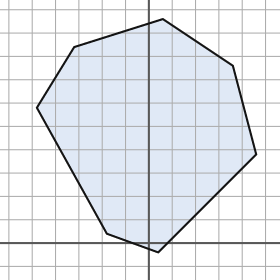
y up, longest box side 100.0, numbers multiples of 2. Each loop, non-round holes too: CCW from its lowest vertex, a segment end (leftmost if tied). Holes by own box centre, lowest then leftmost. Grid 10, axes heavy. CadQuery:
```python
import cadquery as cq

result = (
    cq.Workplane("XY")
    .moveTo(4.0, -4.0)
    .lineTo(46.0, 38.0)
    .lineTo(36.0, 76.0)
    .lineTo(6.0, 96.0)
    .lineTo(-32.0, 84.0)
    .lineTo(-48.0, 58.0)
    .lineTo(-18.0, 4.0)
    .close()
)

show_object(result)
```